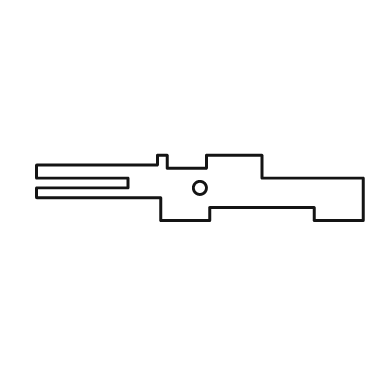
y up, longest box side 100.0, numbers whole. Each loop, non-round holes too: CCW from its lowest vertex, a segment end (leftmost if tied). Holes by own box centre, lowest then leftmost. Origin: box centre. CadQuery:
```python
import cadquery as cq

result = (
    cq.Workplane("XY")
    .moveTo(-12.0, -10.0)
    .lineTo(3.0, -10.0)
    .lineTo(3.0, -6.0)
    .lineTo(35.0, -6.0)
    .lineTo(35.0, -10.0)
    .lineTo(50.0, -10.0)
    .lineTo(50.0, 3.0)
    .lineTo(19.0, 3.0)
    .lineTo(19.0, 10.0)
    .lineTo(2.0, 10.0)
    .lineTo(2.0, 6.0)
    .lineTo(-10.0, 6.0)
    .lineTo(-10.0, 10.0)
    .lineTo(-13.0, 10.0)
    .lineTo(-13.0, 7.0)
    .lineTo(-50.0, 7.0)
    .lineTo(-50.0, 3.0)
    .lineTo(-22.0, 3.0)
    .lineTo(-22.0, 0.0)
    .lineTo(-50.0, 0.0)
    .lineTo(-50.0, -3.0)
    .lineTo(-12.0, -3.0)
    .close()
    .moveTo(0.0, 0.0)
    .circle(2.0)
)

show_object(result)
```